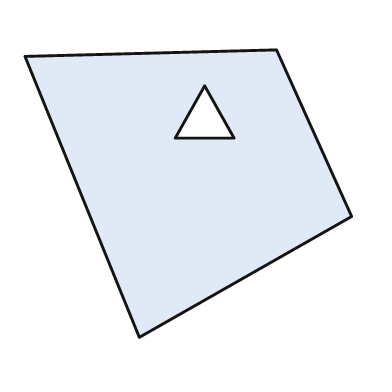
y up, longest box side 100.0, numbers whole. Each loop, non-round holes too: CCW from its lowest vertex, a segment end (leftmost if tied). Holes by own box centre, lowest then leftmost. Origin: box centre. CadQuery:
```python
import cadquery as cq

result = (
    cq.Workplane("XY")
    .moveTo(-15.0, -44.0)
    .lineTo(50.0, -7.0)
    .lineTo(27.0, 44.0)
    .lineTo(-50.0, 42.0)
    .close()
    .moveTo(-4.0, 17.0)
    .lineTo(14.0, 17.0)
    .lineTo(5.0, 33.0)
    .close()
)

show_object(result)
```